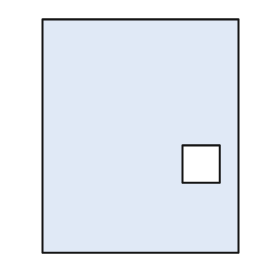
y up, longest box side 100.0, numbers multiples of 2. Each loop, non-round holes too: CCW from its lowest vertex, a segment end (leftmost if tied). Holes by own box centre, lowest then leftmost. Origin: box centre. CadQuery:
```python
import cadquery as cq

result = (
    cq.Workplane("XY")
    .moveTo(-42.0, -50.0)
    .lineTo(42.0, -50.0)
    .lineTo(42.0, 50.0)
    .lineTo(-42.0, 50.0)
    .close()
    .moveTo(18.0, -20.0)
    .lineTo(34.0, -20.0)
    .lineTo(34.0, -4.0)
    .lineTo(18.0, -4.0)
    .close()
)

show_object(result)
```